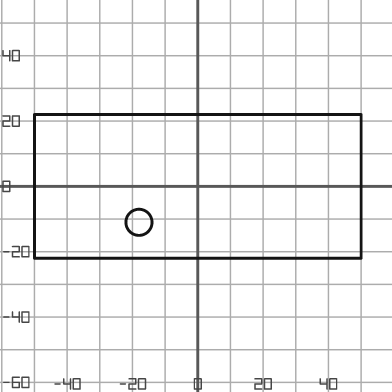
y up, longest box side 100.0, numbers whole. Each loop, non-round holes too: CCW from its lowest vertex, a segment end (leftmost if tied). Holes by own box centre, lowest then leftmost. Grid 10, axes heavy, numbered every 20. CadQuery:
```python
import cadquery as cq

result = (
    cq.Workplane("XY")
    .moveTo(-50.0, -22.0)
    .lineTo(50.0, -22.0)
    .lineTo(50.0, 22.0)
    .lineTo(-50.0, 22.0)
    .close()
    .moveTo(-18.0, -11.0)
    .circle(4.0)
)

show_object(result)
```